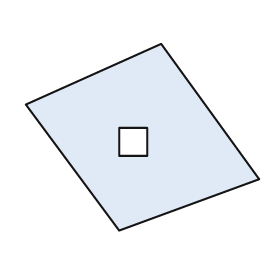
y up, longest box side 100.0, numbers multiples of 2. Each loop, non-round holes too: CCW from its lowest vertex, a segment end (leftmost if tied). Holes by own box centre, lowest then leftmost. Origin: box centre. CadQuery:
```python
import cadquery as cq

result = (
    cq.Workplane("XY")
    .moveTo(-10.0, -40.0)
    .lineTo(50.0, -18.0)
    .lineTo(8.0, 40.0)
    .lineTo(-50.0, 14.0)
    .close()
    .moveTo(-10.0, -8.0)
    .lineTo(2.0, -8.0)
    .lineTo(2.0, 4.0)
    .lineTo(-10.0, 4.0)
    .close()
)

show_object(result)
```